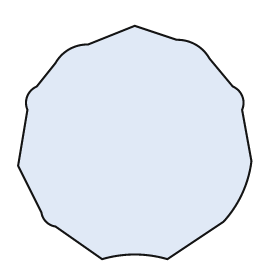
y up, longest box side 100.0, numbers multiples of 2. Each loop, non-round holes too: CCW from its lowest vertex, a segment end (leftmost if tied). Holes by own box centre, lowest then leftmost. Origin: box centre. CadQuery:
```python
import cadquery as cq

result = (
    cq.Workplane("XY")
    .moveTo(-14.0, -50.0)
    .threePointArc((0.0, -48.0), (14.0, -50.0))
    .lineTo(38.0, -34.0)
    .threePointArc((46.0, -22.0), (50.0, -8.0))
    .lineTo(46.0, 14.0)
    .threePointArc((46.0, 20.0), (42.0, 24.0))
    .lineTo(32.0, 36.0)
    .threePointArc((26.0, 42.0), (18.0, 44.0))
    .lineTo(0.0, 50.0)
    .lineTo(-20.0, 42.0)
    .threePointArc((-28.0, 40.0), (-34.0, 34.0))
    .lineTo(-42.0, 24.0)
    .threePointArc((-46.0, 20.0), (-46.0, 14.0))
    .lineTo(-50.0, -10.0)
    .lineTo(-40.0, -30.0)
    .threePointArc((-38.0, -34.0), (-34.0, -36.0))
    .close()
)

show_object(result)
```